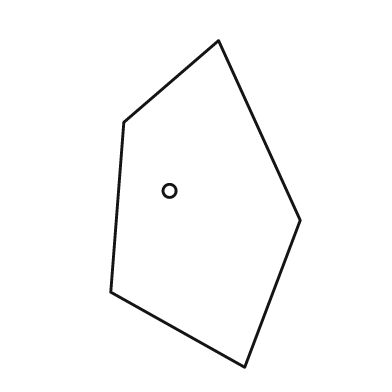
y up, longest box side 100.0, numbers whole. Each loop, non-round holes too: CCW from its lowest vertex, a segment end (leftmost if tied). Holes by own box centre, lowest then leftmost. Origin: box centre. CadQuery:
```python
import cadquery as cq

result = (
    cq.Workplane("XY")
    .moveTo(12.0, -50.0)
    .lineTo(29.0, -5.0)
    .lineTo(4.0, 50.0)
    .lineTo(-25.0, 25.0)
    .lineTo(-29.0, -27.0)
    .close()
    .moveTo(-11.0, 4.0)
    .circle(2.0)
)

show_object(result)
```